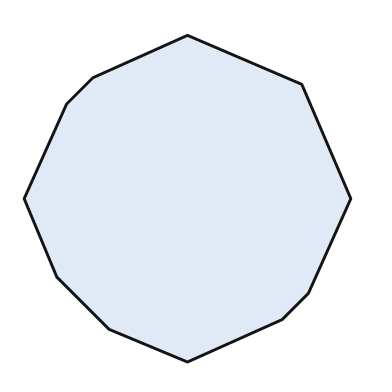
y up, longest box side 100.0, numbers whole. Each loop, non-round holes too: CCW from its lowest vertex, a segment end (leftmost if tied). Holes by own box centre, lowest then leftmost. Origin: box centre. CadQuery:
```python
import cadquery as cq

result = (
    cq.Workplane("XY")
    .moveTo(0.0, -50.0)
    .lineTo(29.0, -37.0)
    .lineTo(37.0, -29.0)
    .lineTo(50.0, 0.0)
    .lineTo(35.0, 35.0)
    .lineTo(0.0, 50.0)
    .lineTo(-29.0, 37.0)
    .lineTo(-37.0, 29.0)
    .lineTo(-50.0, 0.0)
    .lineTo(-40.0, -24.0)
    .lineTo(-24.0, -40.0)
    .close()
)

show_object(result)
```